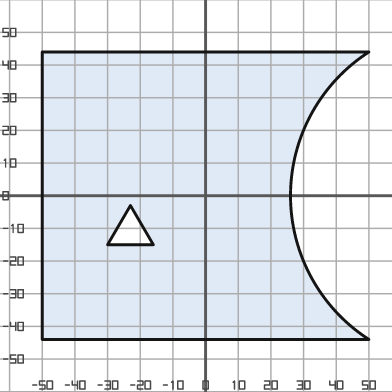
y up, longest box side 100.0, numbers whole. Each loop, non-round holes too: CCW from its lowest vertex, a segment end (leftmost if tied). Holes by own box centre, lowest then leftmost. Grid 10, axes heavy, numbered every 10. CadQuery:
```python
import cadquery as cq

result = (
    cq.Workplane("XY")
    .moveTo(-50.0, -44.0)
    .lineTo(50.0, -44.0)
    .threePointArc((26.0, 0.0), (50.0, 44.0))
    .lineTo(-50.0, 44.0)
    .close()
    .moveTo(-30.0, -15.0)
    .lineTo(-16.0, -15.0)
    .lineTo(-23.0, -3.0)
    .close()
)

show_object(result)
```